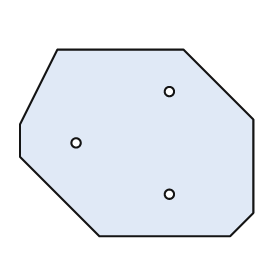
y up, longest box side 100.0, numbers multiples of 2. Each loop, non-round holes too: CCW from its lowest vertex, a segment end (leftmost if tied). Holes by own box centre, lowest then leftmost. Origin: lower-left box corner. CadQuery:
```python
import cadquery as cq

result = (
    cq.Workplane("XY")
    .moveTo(34.0, 0.0)
    .lineTo(90.0, 0.0)
    .lineTo(100.0, 10.0)
    .lineTo(100.0, 50.0)
    .lineTo(70.0, 80.0)
    .lineTo(16.0, 80.0)
    .lineTo(0.0, 48.0)
    .lineTo(0.0, 34.0)
    .close()
    .moveTo(64.0, 18.0)
    .circle(2.0)
    .moveTo(24.0, 40.0)
    .circle(2.0)
    .moveTo(64.0, 62.0)
    .circle(2.0)
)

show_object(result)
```